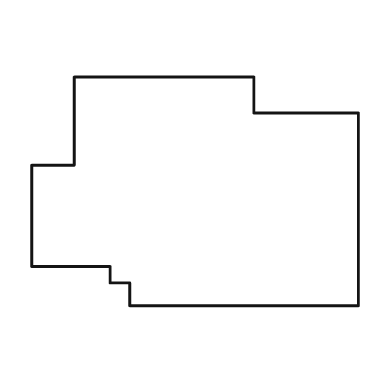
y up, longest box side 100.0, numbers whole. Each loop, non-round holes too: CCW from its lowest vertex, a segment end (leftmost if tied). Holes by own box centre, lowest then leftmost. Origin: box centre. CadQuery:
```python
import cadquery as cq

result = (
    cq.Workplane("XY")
    .moveTo(-20.0, -35.0)
    .lineTo(50.0, -35.0)
    .lineTo(50.0, 24.0)
    .lineTo(18.0, 24.0)
    .lineTo(18.0, 35.0)
    .lineTo(-37.0, 35.0)
    .lineTo(-37.0, 8.0)
    .lineTo(-50.0, 8.0)
    .lineTo(-50.0, -23.0)
    .lineTo(-26.0, -23.0)
    .lineTo(-26.0, -28.0)
    .lineTo(-20.0, -28.0)
    .close()
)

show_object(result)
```